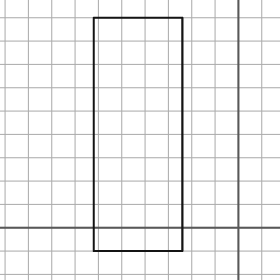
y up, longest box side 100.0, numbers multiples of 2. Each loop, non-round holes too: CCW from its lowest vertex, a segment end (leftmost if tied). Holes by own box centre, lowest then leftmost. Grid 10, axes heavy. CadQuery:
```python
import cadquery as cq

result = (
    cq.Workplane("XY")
    .moveTo(-62.0, -10.0)
    .lineTo(-24.0, -10.0)
    .lineTo(-24.0, 90.0)
    .lineTo(-62.0, 90.0)
    .close()
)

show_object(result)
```